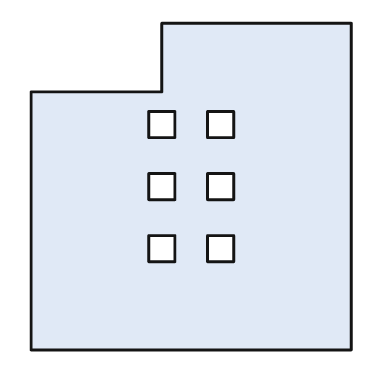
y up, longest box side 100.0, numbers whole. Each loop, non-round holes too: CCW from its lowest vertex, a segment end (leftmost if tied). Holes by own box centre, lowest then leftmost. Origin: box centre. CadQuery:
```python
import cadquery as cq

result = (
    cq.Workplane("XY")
    .moveTo(-49.0, -50.0)
    .lineTo(49.0, -50.0)
    .lineTo(49.0, 50.0)
    .lineTo(-9.0, 50.0)
    .lineTo(-9.0, 29.0)
    .lineTo(-49.0, 29.0)
    .close()
    .moveTo(-13.0, -23.0)
    .lineTo(-5.0, -23.0)
    .lineTo(-5.0, -15.0)
    .lineTo(-13.0, -15.0)
    .close()
    .moveTo(5.0, -23.0)
    .lineTo(13.0, -23.0)
    .lineTo(13.0, -15.0)
    .lineTo(5.0, -15.0)
    .close()
    .moveTo(-13.0, -4.0)
    .lineTo(-5.0, -4.0)
    .lineTo(-5.0, 4.0)
    .lineTo(-13.0, 4.0)
    .close()
    .moveTo(5.0, -4.0)
    .lineTo(13.0, -4.0)
    .lineTo(13.0, 4.0)
    .lineTo(5.0, 4.0)
    .close()
    .moveTo(-13.0, 15.0)
    .lineTo(-5.0, 15.0)
    .lineTo(-5.0, 23.0)
    .lineTo(-13.0, 23.0)
    .close()
    .moveTo(5.0, 15.0)
    .lineTo(13.0, 15.0)
    .lineTo(13.0, 23.0)
    .lineTo(5.0, 23.0)
    .close()
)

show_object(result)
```